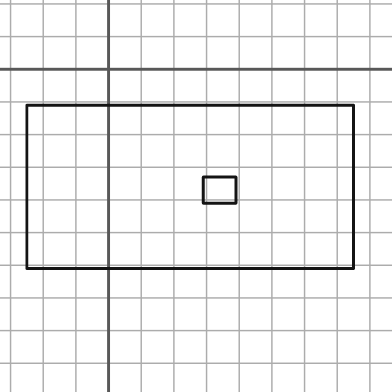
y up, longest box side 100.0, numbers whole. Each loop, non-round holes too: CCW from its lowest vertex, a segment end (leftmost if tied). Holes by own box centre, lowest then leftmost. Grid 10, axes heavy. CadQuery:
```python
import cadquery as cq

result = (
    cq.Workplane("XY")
    .moveTo(-25.0, -61.0)
    .lineTo(75.0, -61.0)
    .lineTo(75.0, -11.0)
    .lineTo(-25.0, -11.0)
    .close()
    .moveTo(29.0, -41.0)
    .lineTo(39.0, -41.0)
    .lineTo(39.0, -33.0)
    .lineTo(29.0, -33.0)
    .close()
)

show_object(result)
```